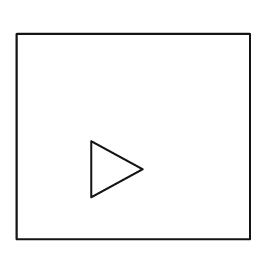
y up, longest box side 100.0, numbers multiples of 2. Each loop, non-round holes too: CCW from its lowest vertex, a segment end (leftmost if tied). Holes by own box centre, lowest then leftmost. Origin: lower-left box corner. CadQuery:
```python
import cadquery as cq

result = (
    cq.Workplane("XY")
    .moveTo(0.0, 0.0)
    .lineTo(100.0, 0.0)
    .lineTo(100.0, 88.0)
    .lineTo(0.0, 88.0)
    .close()
    .moveTo(32.0, 18.0)
    .lineTo(54.0, 30.0)
    .lineTo(32.0, 42.0)
    .close()
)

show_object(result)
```